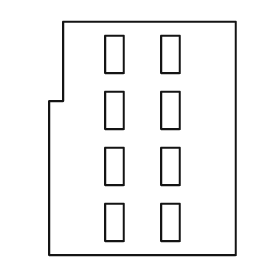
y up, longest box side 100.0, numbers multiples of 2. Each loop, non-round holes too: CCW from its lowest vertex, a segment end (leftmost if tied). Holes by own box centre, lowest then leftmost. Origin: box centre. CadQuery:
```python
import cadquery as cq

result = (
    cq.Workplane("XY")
    .moveTo(-40.0, -50.0)
    .lineTo(40.0, -50.0)
    .lineTo(40.0, 50.0)
    .lineTo(-34.0, 50.0)
    .lineTo(-34.0, 16.0)
    .lineTo(-40.0, 16.0)
    .close()
    .moveTo(-16.0, -44.0)
    .lineTo(-8.0, -44.0)
    .lineTo(-8.0, -28.0)
    .lineTo(-16.0, -28.0)
    .close()
    .moveTo(8.0, -44.0)
    .lineTo(16.0, -44.0)
    .lineTo(16.0, -28.0)
    .lineTo(8.0, -28.0)
    .close()
    .moveTo(-16.0, -20.0)
    .lineTo(-8.0, -20.0)
    .lineTo(-8.0, -4.0)
    .lineTo(-16.0, -4.0)
    .close()
    .moveTo(8.0, -20.0)
    .lineTo(16.0, -20.0)
    .lineTo(16.0, -4.0)
    .lineTo(8.0, -4.0)
    .close()
    .moveTo(-16.0, 4.0)
    .lineTo(-8.0, 4.0)
    .lineTo(-8.0, 20.0)
    .lineTo(-16.0, 20.0)
    .close()
    .moveTo(8.0, 4.0)
    .lineTo(16.0, 4.0)
    .lineTo(16.0, 20.0)
    .lineTo(8.0, 20.0)
    .close()
    .moveTo(-16.0, 28.0)
    .lineTo(-8.0, 28.0)
    .lineTo(-8.0, 44.0)
    .lineTo(-16.0, 44.0)
    .close()
    .moveTo(8.0, 28.0)
    .lineTo(16.0, 28.0)
    .lineTo(16.0, 44.0)
    .lineTo(8.0, 44.0)
    .close()
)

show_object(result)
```